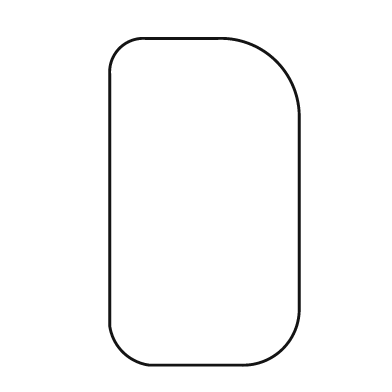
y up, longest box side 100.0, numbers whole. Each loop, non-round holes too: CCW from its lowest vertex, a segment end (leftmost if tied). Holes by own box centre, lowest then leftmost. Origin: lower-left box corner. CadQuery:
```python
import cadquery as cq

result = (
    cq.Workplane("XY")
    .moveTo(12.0, 0.0)
    .lineTo(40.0, 0.0)
    .threePointArc((53.0, 5.0), (58.0, 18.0))
    .lineTo(58.0, 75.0)
    .threePointArc((51.0, 93.0), (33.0, 100.0))
    .lineTo(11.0, 100.0)
    .threePointArc((3.0, 97.0), (0.0, 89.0))
    .lineTo(0.0, 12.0)
    .threePointArc((4.0, 4.0), (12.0, 0.0))
    .close()
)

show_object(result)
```